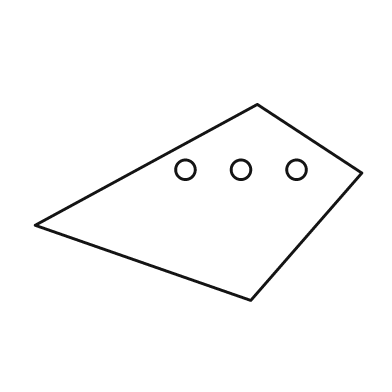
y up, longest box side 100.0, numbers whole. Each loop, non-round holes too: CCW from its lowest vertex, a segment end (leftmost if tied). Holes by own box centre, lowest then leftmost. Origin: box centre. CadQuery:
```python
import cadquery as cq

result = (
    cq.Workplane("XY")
    .moveTo(16.0, -30.0)
    .lineTo(50.0, 9.0)
    .lineTo(18.0, 30.0)
    .lineTo(-50.0, -7.0)
    .close()
    .moveTo(-4.0, 10.0)
    .circle(3.0)
    .moveTo(13.0, 10.0)
    .circle(3.0)
    .moveTo(30.0, 10.0)
    .circle(3.0)
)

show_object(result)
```